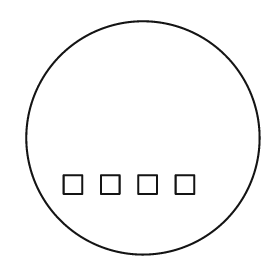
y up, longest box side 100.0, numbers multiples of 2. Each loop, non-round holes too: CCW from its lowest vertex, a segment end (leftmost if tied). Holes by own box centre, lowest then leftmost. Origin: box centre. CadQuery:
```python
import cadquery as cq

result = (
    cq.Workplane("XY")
    .moveTo(0.0, 0.0)
    .circle(50.0)
    .moveTo(-34.0, -24.0)
    .lineTo(-26.0, -24.0)
    .lineTo(-26.0, -16.0)
    .lineTo(-34.0, -16.0)
    .close()
    .moveTo(-18.0, -24.0)
    .lineTo(-10.0, -24.0)
    .lineTo(-10.0, -16.0)
    .lineTo(-18.0, -16.0)
    .close()
    .moveTo(-2.0, -24.0)
    .lineTo(6.0, -24.0)
    .lineTo(6.0, -16.0)
    .lineTo(-2.0, -16.0)
    .close()
    .moveTo(14.0, -24.0)
    .lineTo(22.0, -24.0)
    .lineTo(22.0, -16.0)
    .lineTo(14.0, -16.0)
    .close()
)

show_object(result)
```